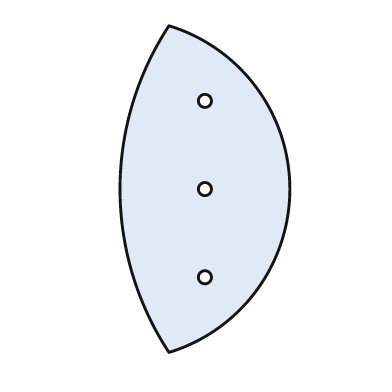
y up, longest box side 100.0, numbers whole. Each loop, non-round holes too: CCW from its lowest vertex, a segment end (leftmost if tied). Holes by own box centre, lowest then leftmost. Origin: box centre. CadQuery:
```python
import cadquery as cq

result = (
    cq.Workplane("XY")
    .moveTo(-11.0, -50.0)
    .threePointArc((26.0, 0.0), (-11.0, 50.0))
    .threePointArc((-26.0, 0.0), (-11.0, -50.0))
    .close()
    .moveTo(0.0, -27.0)
    .circle(2.0)
    .moveTo(0.0, 0.0)
    .circle(2.0)
    .moveTo(0.0, 27.0)
    .circle(2.0)
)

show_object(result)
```